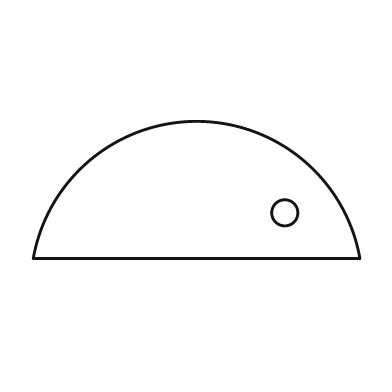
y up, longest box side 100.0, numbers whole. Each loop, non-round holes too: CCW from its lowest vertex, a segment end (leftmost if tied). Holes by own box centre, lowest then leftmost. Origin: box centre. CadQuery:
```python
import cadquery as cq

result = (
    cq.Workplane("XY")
    .moveTo(-50.0, -21.0)
    .lineTo(50.0, -21.0)
    .threePointArc((0.0, 21.0), (-50.0, -21.0))
    .close()
    .moveTo(27.0, -7.0)
    .circle(4.0)
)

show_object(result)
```